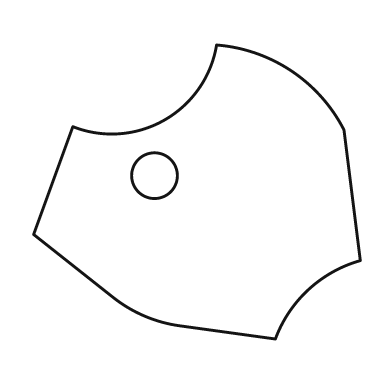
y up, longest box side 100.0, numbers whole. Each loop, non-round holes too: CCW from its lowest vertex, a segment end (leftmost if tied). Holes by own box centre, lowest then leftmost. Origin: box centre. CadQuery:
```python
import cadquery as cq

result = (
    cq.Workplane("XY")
    .moveTo(24.0, -45.0)
    .threePointArc((34.0, -30.0), (50.0, -21.0))
    .lineTo(45.0, 19.0)
    .threePointArc((29.0, 37.0), (6.0, 45.0))
    .threePointArc((-10.0, 22.0), (-38.0, 20.0))
    .lineTo(-50.0, -13.0)
    .lineTo(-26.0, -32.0)
    .threePointArc((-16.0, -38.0), (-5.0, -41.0))
    .close()
    .moveTo(-13.0, 5.0)
    .circle(7.0)
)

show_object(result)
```